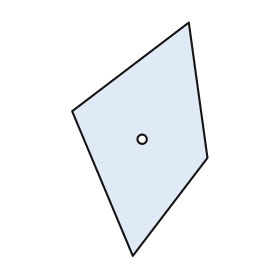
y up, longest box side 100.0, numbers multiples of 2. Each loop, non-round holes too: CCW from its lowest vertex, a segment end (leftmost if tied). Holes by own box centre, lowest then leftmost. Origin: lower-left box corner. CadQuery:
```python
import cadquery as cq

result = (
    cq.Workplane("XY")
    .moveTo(26.0, 0.0)
    .lineTo(58.0, 42.0)
    .lineTo(50.0, 100.0)
    .lineTo(0.0, 62.0)
    .close()
    .moveTo(30.0, 50.0)
    .circle(2.0)
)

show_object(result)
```